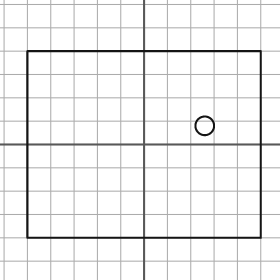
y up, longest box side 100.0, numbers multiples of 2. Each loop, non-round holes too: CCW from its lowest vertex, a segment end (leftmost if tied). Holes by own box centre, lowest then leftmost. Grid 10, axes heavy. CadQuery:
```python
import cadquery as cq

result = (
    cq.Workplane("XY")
    .moveTo(-50.0, -40.0)
    .lineTo(50.0, -40.0)
    .lineTo(50.0, 40.0)
    .lineTo(-50.0, 40.0)
    .close()
    .moveTo(26.0, 8.0)
    .circle(4.0)
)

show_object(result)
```